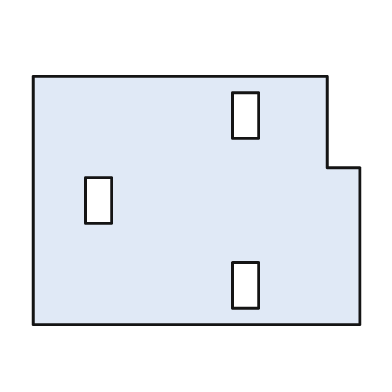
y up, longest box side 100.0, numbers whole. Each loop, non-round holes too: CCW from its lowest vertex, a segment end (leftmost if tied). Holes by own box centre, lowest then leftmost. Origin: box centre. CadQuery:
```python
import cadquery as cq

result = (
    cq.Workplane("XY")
    .moveTo(-50.0, -38.0)
    .lineTo(50.0, -38.0)
    .lineTo(50.0, 10.0)
    .lineTo(40.0, 10.0)
    .lineTo(40.0, 38.0)
    .lineTo(-50.0, 38.0)
    .close()
    .moveTo(11.0, -33.0)
    .lineTo(19.0, -33.0)
    .lineTo(19.0, -19.0)
    .lineTo(11.0, -19.0)
    .close()
    .moveTo(-34.0, -7.0)
    .lineTo(-26.0, -7.0)
    .lineTo(-26.0, 7.0)
    .lineTo(-34.0, 7.0)
    .close()
    .moveTo(11.0, 19.0)
    .lineTo(19.0, 19.0)
    .lineTo(19.0, 33.0)
    .lineTo(11.0, 33.0)
    .close()
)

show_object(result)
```